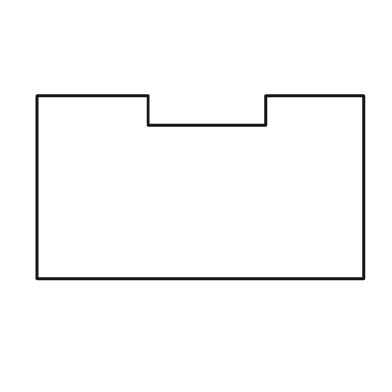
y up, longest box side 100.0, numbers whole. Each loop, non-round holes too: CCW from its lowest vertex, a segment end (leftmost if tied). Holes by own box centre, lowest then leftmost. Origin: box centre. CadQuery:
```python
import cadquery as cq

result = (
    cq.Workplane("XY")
    .moveTo(-50.0, -28.0)
    .lineTo(50.0, -28.0)
    .lineTo(50.0, 28.0)
    .lineTo(20.0, 28.0)
    .lineTo(20.0, 19.0)
    .lineTo(-16.0, 19.0)
    .lineTo(-16.0, 28.0)
    .lineTo(-50.0, 28.0)
    .close()
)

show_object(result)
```